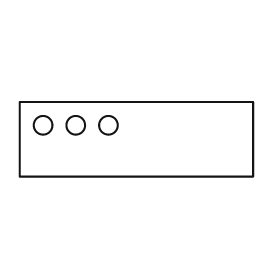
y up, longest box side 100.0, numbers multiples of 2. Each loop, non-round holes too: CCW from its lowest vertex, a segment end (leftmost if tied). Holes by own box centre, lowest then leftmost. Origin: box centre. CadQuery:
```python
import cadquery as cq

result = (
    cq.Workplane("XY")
    .moveTo(-50.0, -16.0)
    .lineTo(50.0, -16.0)
    .lineTo(50.0, 16.0)
    .lineTo(-50.0, 16.0)
    .close()
    .moveTo(-40.0, 6.0)
    .circle(4.0)
    .moveTo(-26.0, 6.0)
    .circle(4.0)
    .moveTo(-12.0, 6.0)
    .circle(4.0)
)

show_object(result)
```